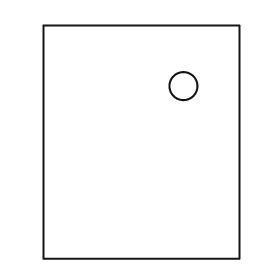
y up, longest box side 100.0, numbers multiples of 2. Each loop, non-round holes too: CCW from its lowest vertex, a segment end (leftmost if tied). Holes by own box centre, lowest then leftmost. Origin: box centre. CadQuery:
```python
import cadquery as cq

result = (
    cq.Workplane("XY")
    .moveTo(-42.0, -50.0)
    .lineTo(42.0, -50.0)
    .lineTo(42.0, 50.0)
    .lineTo(-42.0, 50.0)
    .close()
    .moveTo(18.0, 24.0)
    .circle(6.0)
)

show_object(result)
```